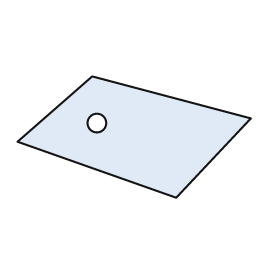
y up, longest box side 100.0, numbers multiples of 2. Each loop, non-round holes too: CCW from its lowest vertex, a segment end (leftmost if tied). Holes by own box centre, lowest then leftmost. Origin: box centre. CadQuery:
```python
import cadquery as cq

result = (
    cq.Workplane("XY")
    .moveTo(18.0, -26.0)
    .lineTo(50.0, 8.0)
    .lineTo(-18.0, 26.0)
    .lineTo(-50.0, -2.0)
    .close()
    .moveTo(-16.0, 6.0)
    .circle(4.0)
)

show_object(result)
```